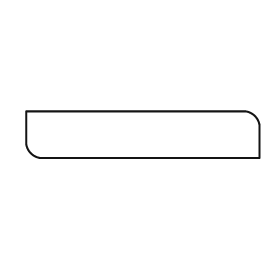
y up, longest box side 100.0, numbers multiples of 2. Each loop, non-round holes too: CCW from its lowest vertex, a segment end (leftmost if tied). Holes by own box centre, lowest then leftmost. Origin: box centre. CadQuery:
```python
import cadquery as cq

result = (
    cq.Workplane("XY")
    .moveTo(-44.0, -10.0)
    .lineTo(50.0, -10.0)
    .lineTo(50.0, 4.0)
    .threePointArc((48.0, 8.0), (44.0, 10.0))
    .lineTo(-50.0, 10.0)
    .lineTo(-50.0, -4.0)
    .threePointArc((-48.0, -8.0), (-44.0, -10.0))
    .close()
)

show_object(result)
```